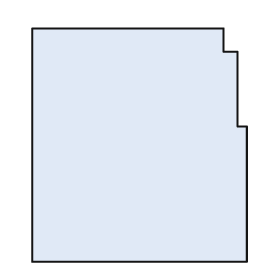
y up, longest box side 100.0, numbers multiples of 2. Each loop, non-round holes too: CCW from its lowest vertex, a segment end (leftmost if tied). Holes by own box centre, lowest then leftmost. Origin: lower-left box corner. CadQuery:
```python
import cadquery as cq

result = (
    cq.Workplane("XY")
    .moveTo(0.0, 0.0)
    .lineTo(92.0, 0.0)
    .lineTo(92.0, 58.0)
    .lineTo(88.0, 58.0)
    .lineTo(88.0, 90.0)
    .lineTo(82.0, 90.0)
    .lineTo(82.0, 100.0)
    .lineTo(0.0, 100.0)
    .close()
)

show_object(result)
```